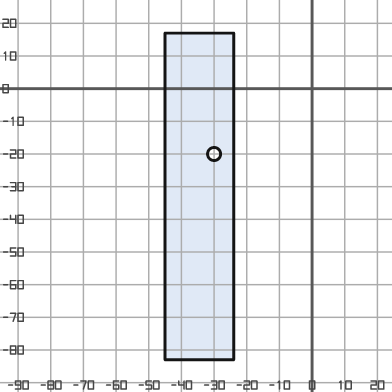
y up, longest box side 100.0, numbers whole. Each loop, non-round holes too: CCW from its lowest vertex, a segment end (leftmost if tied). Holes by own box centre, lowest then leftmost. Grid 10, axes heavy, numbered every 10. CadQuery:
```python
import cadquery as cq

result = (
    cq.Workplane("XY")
    .moveTo(-45.0, -83.0)
    .lineTo(-24.0, -83.0)
    .lineTo(-24.0, 17.0)
    .lineTo(-45.0, 17.0)
    .close()
    .moveTo(-30.0, -20.0)
    .circle(2.0)
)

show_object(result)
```